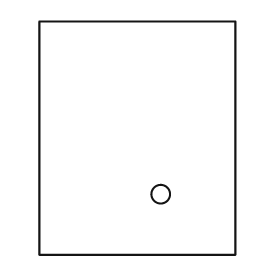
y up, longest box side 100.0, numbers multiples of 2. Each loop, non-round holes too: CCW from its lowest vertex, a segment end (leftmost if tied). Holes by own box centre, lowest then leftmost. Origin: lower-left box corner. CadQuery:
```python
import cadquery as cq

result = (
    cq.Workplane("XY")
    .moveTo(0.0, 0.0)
    .lineTo(84.0, 0.0)
    .lineTo(84.0, 100.0)
    .lineTo(0.0, 100.0)
    .close()
    .moveTo(52.0, 26.0)
    .circle(4.0)
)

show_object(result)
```